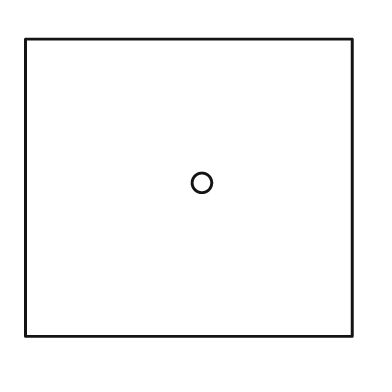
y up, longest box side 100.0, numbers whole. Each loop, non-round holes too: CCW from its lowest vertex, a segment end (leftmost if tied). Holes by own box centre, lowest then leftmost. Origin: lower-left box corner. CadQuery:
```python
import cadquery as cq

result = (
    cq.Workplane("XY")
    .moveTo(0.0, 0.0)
    .lineTo(100.0, 0.0)
    .lineTo(100.0, 91.0)
    .lineTo(0.0, 91.0)
    .close()
    .moveTo(54.0, 47.0)
    .circle(3.0)
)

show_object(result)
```